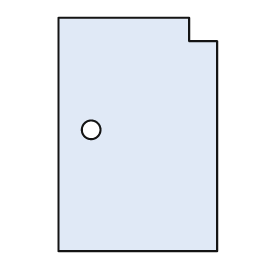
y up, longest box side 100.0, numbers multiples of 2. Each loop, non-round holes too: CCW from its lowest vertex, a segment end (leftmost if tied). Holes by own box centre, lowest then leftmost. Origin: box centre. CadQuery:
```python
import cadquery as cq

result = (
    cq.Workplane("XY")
    .moveTo(-34.0, -50.0)
    .lineTo(34.0, -50.0)
    .lineTo(34.0, 40.0)
    .lineTo(22.0, 40.0)
    .lineTo(22.0, 50.0)
    .lineTo(-34.0, 50.0)
    .close()
    .moveTo(-20.0, 2.0)
    .circle(4.0)
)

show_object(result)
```